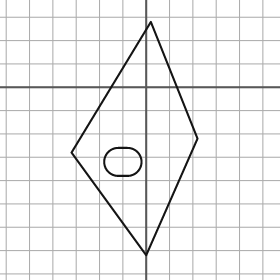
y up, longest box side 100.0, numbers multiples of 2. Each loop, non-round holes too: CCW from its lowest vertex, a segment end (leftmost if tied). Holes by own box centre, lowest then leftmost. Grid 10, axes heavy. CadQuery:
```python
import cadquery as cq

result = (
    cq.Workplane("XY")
    .moveTo(0.0, -72.0)
    .lineTo(22.0, -22.0)
    .lineTo(2.0, 28.0)
    .lineTo(-32.0, -28.0)
    .close()
    .moveTo(-12.0, -38.0)
    .lineTo(-8.0, -38.0)
    .threePointArc((-2.0, -32.0), (-8.0, -26.0))
    .lineTo(-12.0, -26.0)
    .threePointArc((-18.0, -32.0), (-12.0, -38.0))
    .close()
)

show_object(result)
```